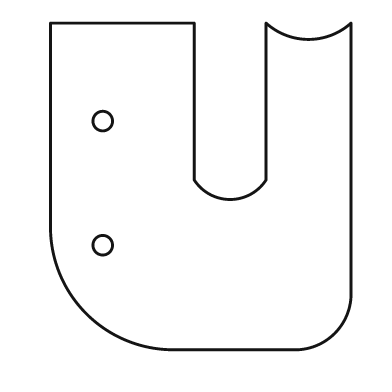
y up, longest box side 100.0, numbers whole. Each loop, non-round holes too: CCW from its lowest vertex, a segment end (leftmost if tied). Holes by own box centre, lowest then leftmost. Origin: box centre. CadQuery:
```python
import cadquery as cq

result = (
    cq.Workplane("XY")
    .moveTo(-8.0, -50.0)
    .lineTo(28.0, -50.0)
    .threePointArc((41.0, -45.0), (46.0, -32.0))
    .lineTo(46.0, 50.0)
    .threePointArc((33.0, 45.0), (20.0, 50.0))
    .lineTo(20.0, 2.0)
    .threePointArc((9.0, -4.0), (-2.0, 2.0))
    .lineTo(-2.0, 50.0)
    .lineTo(-46.0, 50.0)
    .lineTo(-46.0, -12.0)
    .threePointArc((-35.0, -39.0), (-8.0, -50.0))
    .close()
    .moveTo(-30.0, -18.0)
    .circle(3.0)
    .moveTo(-30.0, 20.0)
    .circle(3.0)
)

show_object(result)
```